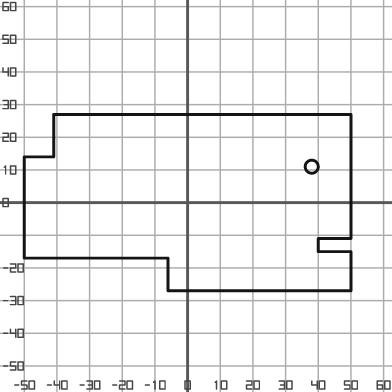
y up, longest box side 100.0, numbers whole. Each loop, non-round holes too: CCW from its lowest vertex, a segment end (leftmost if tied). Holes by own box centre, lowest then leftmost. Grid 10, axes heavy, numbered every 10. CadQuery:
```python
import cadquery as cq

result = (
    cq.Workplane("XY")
    .moveTo(-6.0, -27.0)
    .lineTo(50.0, -27.0)
    .lineTo(50.0, -15.0)
    .lineTo(40.0, -15.0)
    .lineTo(40.0, -11.0)
    .lineTo(50.0, -11.0)
    .lineTo(50.0, 27.0)
    .lineTo(-41.0, 27.0)
    .lineTo(-41.0, 14.0)
    .lineTo(-50.0, 14.0)
    .lineTo(-50.0, -17.0)
    .lineTo(-6.0, -17.0)
    .close()
    .moveTo(38.0, 11.0)
    .circle(2.0)
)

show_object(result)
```